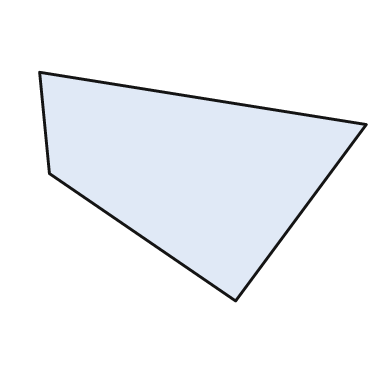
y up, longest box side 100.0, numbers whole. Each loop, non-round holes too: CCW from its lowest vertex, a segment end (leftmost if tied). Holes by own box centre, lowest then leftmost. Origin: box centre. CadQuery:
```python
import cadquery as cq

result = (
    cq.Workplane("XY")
    .moveTo(10.0, -35.0)
    .lineTo(50.0, 19.0)
    .lineTo(-50.0, 35.0)
    .lineTo(-47.0, 4.0)
    .close()
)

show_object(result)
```